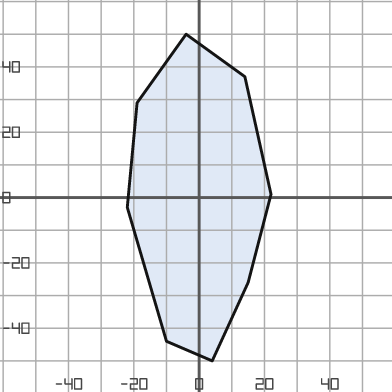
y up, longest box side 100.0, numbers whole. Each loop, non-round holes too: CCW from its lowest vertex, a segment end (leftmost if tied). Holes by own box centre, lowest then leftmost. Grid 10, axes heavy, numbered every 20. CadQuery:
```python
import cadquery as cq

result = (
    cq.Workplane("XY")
    .moveTo(4.0, -50.0)
    .lineTo(15.0, -26.0)
    .lineTo(22.0, 1.0)
    .lineTo(14.0, 37.0)
    .lineTo(-4.0, 50.0)
    .lineTo(-19.0, 29.0)
    .lineTo(-22.0, -3.0)
    .lineTo(-10.0, -44.0)
    .close()
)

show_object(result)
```